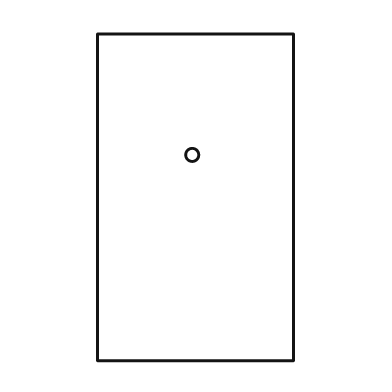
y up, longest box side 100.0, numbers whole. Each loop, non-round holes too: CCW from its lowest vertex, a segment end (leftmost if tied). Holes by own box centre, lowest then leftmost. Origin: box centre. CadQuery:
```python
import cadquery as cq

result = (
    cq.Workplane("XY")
    .moveTo(-30.0, -50.0)
    .lineTo(30.0, -50.0)
    .lineTo(30.0, 50.0)
    .lineTo(-30.0, 50.0)
    .close()
    .moveTo(-1.0, 13.0)
    .circle(2.0)
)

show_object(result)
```